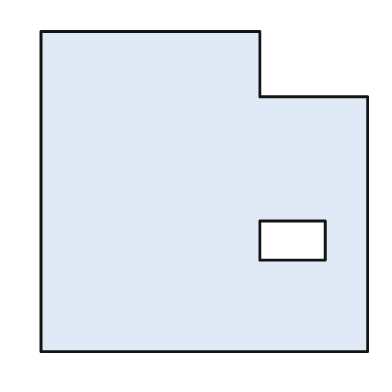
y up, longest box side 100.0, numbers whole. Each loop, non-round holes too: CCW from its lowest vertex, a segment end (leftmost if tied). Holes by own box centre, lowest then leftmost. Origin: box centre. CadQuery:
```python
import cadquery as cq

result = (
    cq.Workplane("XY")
    .moveTo(-50.0, -49.0)
    .lineTo(50.0, -49.0)
    .lineTo(50.0, 29.0)
    .lineTo(17.0, 29.0)
    .lineTo(17.0, 49.0)
    .lineTo(-50.0, 49.0)
    .close()
    .moveTo(17.0, -21.0)
    .lineTo(37.0, -21.0)
    .lineTo(37.0, -9.0)
    .lineTo(17.0, -9.0)
    .close()
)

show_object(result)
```